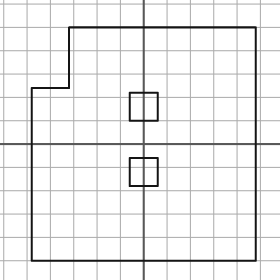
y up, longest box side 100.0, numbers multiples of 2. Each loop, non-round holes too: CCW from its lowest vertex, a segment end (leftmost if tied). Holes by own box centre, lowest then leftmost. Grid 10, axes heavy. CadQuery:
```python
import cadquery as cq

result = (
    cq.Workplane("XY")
    .moveTo(-48.0, -50.0)
    .lineTo(48.0, -50.0)
    .lineTo(48.0, 50.0)
    .lineTo(-32.0, 50.0)
    .lineTo(-32.0, 24.0)
    .lineTo(-48.0, 24.0)
    .close()
    .moveTo(-6.0, -18.0)
    .lineTo(6.0, -18.0)
    .lineTo(6.0, -6.0)
    .lineTo(-6.0, -6.0)
    .close()
    .moveTo(-6.0, 10.0)
    .lineTo(6.0, 10.0)
    .lineTo(6.0, 22.0)
    .lineTo(-6.0, 22.0)
    .close()
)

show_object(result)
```